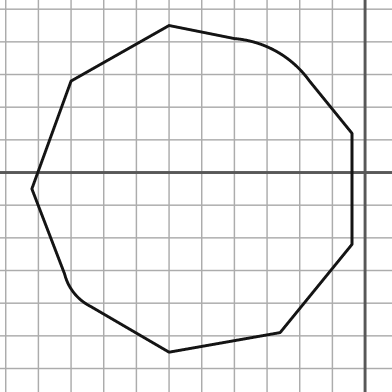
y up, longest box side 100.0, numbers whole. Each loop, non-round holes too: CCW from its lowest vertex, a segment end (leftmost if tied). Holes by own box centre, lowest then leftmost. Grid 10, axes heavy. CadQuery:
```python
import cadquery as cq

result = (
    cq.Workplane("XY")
    .moveTo(-60.0, -55.0)
    .lineTo(-26.0, -49.0)
    .lineTo(-4.0, -22.0)
    .lineTo(-4.0, 12.0)
    .lineTo(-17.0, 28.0)
    .threePointArc((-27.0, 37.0), (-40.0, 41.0))
    .lineTo(-60.0, 45.0)
    .lineTo(-90.0, 28.0)
    .lineTo(-102.0, -5.0)
    .lineTo(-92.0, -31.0)
    .threePointArc((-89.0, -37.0), (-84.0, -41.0))
    .close()
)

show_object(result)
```